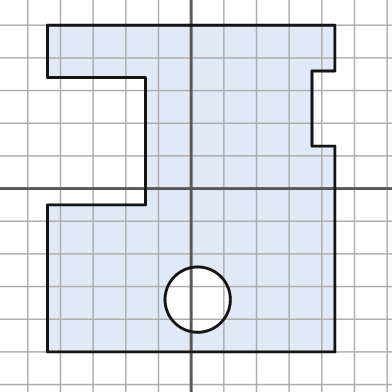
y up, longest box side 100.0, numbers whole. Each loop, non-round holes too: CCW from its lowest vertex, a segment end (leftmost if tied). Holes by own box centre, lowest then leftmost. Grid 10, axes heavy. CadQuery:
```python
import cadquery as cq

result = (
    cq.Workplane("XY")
    .moveTo(-44.0, -50.0)
    .lineTo(44.0, -50.0)
    .lineTo(44.0, 13.0)
    .lineTo(37.0, 13.0)
    .lineTo(37.0, 36.0)
    .lineTo(44.0, 36.0)
    .lineTo(44.0, 50.0)
    .lineTo(-44.0, 50.0)
    .lineTo(-44.0, 34.0)
    .lineTo(-14.0, 34.0)
    .lineTo(-14.0, -5.0)
    .lineTo(-44.0, -5.0)
    .close()
    .moveTo(2.0, -34.0)
    .circle(10.0)
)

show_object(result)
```